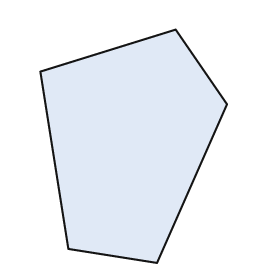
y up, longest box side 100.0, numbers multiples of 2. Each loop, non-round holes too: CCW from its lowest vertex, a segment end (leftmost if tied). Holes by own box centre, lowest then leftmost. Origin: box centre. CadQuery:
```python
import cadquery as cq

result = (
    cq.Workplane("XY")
    .moveTo(10.0, -50.0)
    .lineTo(40.0, 18.0)
    .lineTo(18.0, 50.0)
    .lineTo(-40.0, 32.0)
    .lineTo(-28.0, -44.0)
    .close()
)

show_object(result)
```